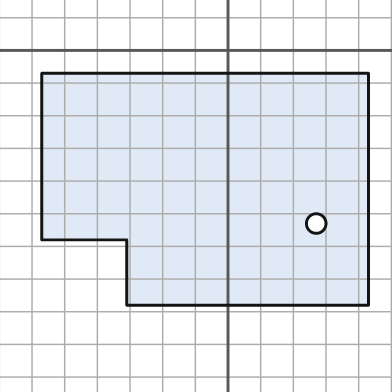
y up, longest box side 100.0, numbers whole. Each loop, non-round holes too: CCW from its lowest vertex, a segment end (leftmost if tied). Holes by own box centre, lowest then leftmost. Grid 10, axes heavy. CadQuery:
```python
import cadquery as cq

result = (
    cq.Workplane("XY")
    .moveTo(-31.0, -78.0)
    .lineTo(43.0, -78.0)
    .lineTo(43.0, -7.0)
    .lineTo(-57.0, -7.0)
    .lineTo(-57.0, -58.0)
    .lineTo(-31.0, -58.0)
    .close()
    .moveTo(27.0, -53.0)
    .circle(3.0)
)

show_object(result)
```